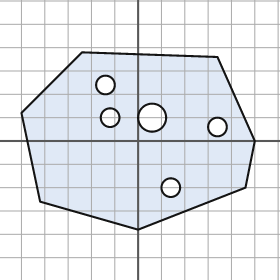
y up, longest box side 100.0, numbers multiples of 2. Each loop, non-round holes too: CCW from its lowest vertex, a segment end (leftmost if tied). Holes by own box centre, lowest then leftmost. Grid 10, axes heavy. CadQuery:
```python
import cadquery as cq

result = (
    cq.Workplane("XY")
    .moveTo(0.0, -38.0)
    .lineTo(46.0, -20.0)
    .lineTo(50.0, 0.0)
    .lineTo(34.0, 36.0)
    .lineTo(-24.0, 38.0)
    .lineTo(-50.0, 12.0)
    .lineTo(-42.0, -26.0)
    .close()
    .moveTo(14.0, -20.0)
    .circle(4.0)
    .moveTo(34.0, 6.0)
    .circle(4.0)
    .moveTo(-12.0, 10.0)
    .circle(4.0)
    .moveTo(6.0, 10.0)
    .circle(6.0)
    .moveTo(-14.0, 24.0)
    .circle(4.0)
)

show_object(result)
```